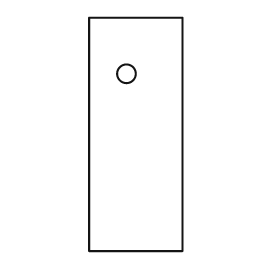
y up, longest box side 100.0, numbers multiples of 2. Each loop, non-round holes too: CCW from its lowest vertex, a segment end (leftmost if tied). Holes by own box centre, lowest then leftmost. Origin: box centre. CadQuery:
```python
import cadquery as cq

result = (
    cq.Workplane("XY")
    .moveTo(-20.0, -50.0)
    .lineTo(20.0, -50.0)
    .lineTo(20.0, 50.0)
    .lineTo(-20.0, 50.0)
    .close()
    .moveTo(-4.0, 26.0)
    .circle(4.0)
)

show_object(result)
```